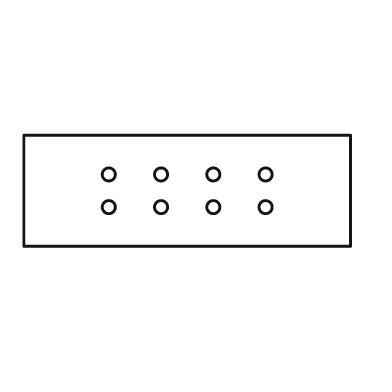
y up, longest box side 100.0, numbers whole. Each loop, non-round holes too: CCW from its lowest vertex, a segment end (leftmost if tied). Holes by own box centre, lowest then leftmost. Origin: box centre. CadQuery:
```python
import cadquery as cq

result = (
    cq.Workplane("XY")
    .moveTo(-50.0, -17.0)
    .lineTo(50.0, -17.0)
    .lineTo(50.0, 17.0)
    .lineTo(-50.0, 17.0)
    .close()
    .moveTo(-24.0, -5.0)
    .circle(2.0)
    .moveTo(-8.0, -5.0)
    .circle(2.0)
    .moveTo(8.0, -5.0)
    .circle(2.0)
    .moveTo(24.0, -5.0)
    .circle(2.0)
    .moveTo(-24.0, 5.0)
    .circle(2.0)
    .moveTo(-8.0, 5.0)
    .circle(2.0)
    .moveTo(8.0, 5.0)
    .circle(2.0)
    .moveTo(24.0, 5.0)
    .circle(2.0)
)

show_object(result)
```